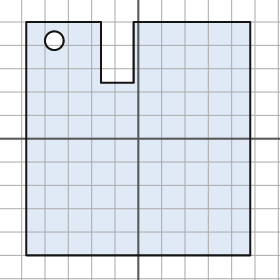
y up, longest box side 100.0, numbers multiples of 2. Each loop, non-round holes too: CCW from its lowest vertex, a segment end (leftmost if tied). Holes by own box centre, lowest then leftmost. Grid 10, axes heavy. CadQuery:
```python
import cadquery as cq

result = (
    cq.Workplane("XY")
    .moveTo(-48.0, -50.0)
    .lineTo(48.0, -50.0)
    .lineTo(48.0, 50.0)
    .lineTo(-2.0, 50.0)
    .lineTo(-2.0, 24.0)
    .lineTo(-16.0, 24.0)
    .lineTo(-16.0, 50.0)
    .lineTo(-48.0, 50.0)
    .close()
    .moveTo(-36.0, 42.0)
    .circle(4.0)
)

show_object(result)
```